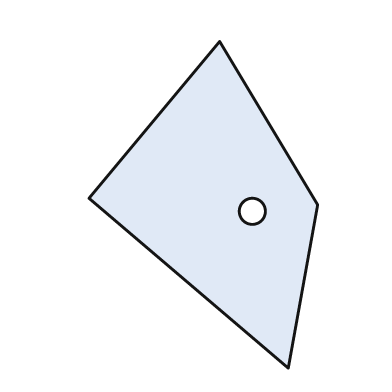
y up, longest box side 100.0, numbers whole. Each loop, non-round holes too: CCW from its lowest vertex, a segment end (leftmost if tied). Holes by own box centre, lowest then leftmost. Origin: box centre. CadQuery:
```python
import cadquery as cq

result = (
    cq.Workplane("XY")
    .moveTo(26.0, -50.0)
    .lineTo(35.0, 0.0)
    .lineTo(5.0, 50.0)
    .lineTo(-35.0, 2.0)
    .close()
    .moveTo(15.0, -2.0)
    .circle(4.0)
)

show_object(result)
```